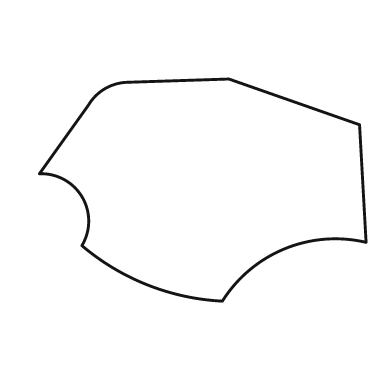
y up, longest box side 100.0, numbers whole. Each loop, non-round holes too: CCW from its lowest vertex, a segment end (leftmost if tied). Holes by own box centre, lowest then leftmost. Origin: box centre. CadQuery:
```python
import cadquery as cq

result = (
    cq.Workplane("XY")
    .moveTo(6.0, -34.0)
    .threePointArc((25.0, -18.0), (50.0, -16.0))
    .lineTo(48.0, 20.0)
    .lineTo(8.0, 34.0)
    .lineTo(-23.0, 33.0)
    .threePointArc((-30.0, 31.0), (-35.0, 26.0))
    .lineTo(-50.0, 5.0)
    .threePointArc((-37.0, -2.0), (-37.0, -17.0))
    .threePointArc((-17.0, -29.0), (6.0, -34.0))
    .close()
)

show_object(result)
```